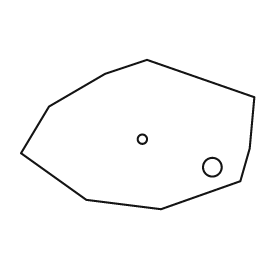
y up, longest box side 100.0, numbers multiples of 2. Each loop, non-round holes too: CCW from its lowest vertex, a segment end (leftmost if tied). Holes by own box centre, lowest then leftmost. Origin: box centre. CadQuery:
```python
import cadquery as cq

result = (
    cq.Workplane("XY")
    .moveTo(10.0, -32.0)
    .lineTo(44.0, -20.0)
    .lineTo(48.0, -6.0)
    .lineTo(50.0, 16.0)
    .lineTo(4.0, 32.0)
    .lineTo(-14.0, 26.0)
    .lineTo(-38.0, 12.0)
    .lineTo(-50.0, -8.0)
    .lineTo(-22.0, -28.0)
    .close()
    .moveTo(32.0, -14.0)
    .circle(4.0)
    .moveTo(2.0, -2.0)
    .circle(2.0)
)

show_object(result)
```